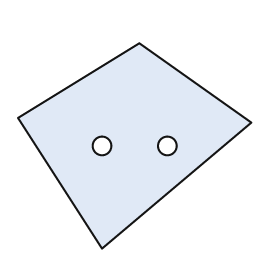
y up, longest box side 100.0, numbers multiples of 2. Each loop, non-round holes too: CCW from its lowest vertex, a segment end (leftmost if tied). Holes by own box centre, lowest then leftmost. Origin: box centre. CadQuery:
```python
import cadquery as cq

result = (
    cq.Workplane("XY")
    .moveTo(-14.0, -44.0)
    .lineTo(50.0, 10.0)
    .lineTo(2.0, 44.0)
    .lineTo(-50.0, 12.0)
    .close()
    .moveTo(-14.0, 0.0)
    .circle(4.0)
    .moveTo(14.0, 0.0)
    .circle(4.0)
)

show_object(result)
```